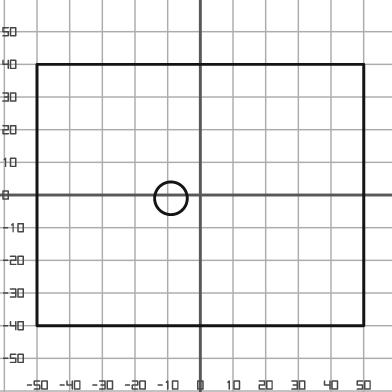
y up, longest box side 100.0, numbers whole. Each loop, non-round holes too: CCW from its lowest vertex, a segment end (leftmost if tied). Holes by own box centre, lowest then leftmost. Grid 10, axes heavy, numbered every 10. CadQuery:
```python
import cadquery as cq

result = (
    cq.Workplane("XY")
    .moveTo(-50.0, -40.0)
    .lineTo(50.0, -40.0)
    .lineTo(50.0, 40.0)
    .lineTo(-50.0, 40.0)
    .close()
    .moveTo(-9.0, -1.0)
    .circle(5.0)
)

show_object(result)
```